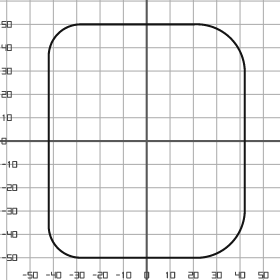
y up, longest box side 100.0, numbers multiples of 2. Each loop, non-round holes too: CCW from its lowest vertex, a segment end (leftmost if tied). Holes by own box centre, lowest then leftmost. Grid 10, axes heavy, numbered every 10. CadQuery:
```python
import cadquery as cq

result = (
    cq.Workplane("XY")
    .moveTo(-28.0, -50.0)
    .lineTo(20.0, -50.0)
    .threePointArc((36.0, -44.0), (42.0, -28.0))
    .lineTo(42.0, 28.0)
    .threePointArc((36.0, 44.0), (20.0, 50.0))
    .lineTo(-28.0, 50.0)
    .threePointArc((-38.0, 46.0), (-42.0, 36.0))
    .lineTo(-42.0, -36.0)
    .threePointArc((-38.0, -46.0), (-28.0, -50.0))
    .close()
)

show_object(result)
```